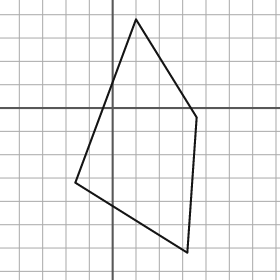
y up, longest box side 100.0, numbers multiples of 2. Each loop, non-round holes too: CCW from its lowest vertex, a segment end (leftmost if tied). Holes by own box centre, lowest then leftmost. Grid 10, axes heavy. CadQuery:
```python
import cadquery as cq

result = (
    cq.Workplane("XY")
    .moveTo(32.0, -62.0)
    .lineTo(36.0, -4.0)
    .lineTo(10.0, 38.0)
    .lineTo(-16.0, -32.0)
    .close()
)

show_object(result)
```